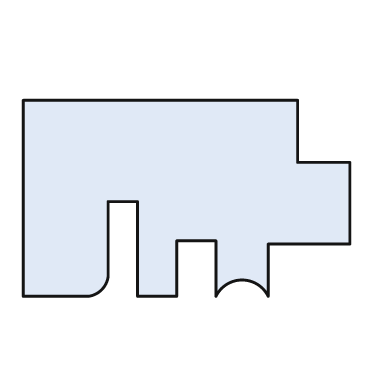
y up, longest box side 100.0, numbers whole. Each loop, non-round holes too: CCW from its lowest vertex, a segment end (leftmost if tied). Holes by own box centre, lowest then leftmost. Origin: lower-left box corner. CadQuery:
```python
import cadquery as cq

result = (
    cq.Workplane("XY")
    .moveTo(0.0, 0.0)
    .lineTo(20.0, 0.0)
    .threePointArc((24.0, 2.0), (26.0, 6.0))
    .lineTo(26.0, 29.0)
    .lineTo(35.0, 29.0)
    .lineTo(35.0, 0.0)
    .lineTo(47.0, 0.0)
    .lineTo(47.0, 17.0)
    .lineTo(59.0, 17.0)
    .lineTo(59.0, 0.0)
    .threePointArc((67.0, 5.0), (75.0, 0.0))
    .lineTo(75.0, 16.0)
    .lineTo(100.0, 16.0)
    .lineTo(100.0, 41.0)
    .lineTo(84.0, 41.0)
    .lineTo(84.0, 60.0)
    .lineTo(0.0, 60.0)
    .close()
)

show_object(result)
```